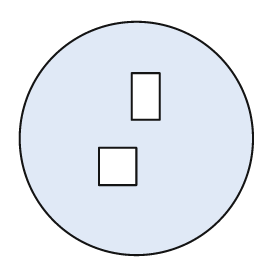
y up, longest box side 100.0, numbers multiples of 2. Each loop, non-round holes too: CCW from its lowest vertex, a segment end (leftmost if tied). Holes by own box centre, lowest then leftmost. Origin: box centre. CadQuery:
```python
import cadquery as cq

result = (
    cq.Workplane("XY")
    .moveTo(0.0, 0.0)
    .circle(50.0)
    .moveTo(-16.0, -20.0)
    .lineTo(0.0, -20.0)
    .lineTo(0.0, -4.0)
    .lineTo(-16.0, -4.0)
    .close()
    .moveTo(-2.0, 8.0)
    .lineTo(10.0, 8.0)
    .lineTo(10.0, 28.0)
    .lineTo(-2.0, 28.0)
    .close()
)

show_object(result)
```